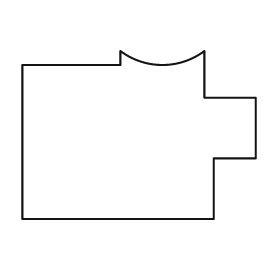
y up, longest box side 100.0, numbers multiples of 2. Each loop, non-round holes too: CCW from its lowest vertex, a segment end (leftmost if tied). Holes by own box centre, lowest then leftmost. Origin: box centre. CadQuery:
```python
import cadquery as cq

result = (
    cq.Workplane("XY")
    .moveTo(-50.0, -36.0)
    .lineTo(32.0, -36.0)
    .lineTo(32.0, -10.0)
    .lineTo(50.0, -10.0)
    .lineTo(50.0, 16.0)
    .lineTo(28.0, 16.0)
    .lineTo(28.0, 36.0)
    .threePointArc((10.0, 30.0), (-8.0, 36.0))
    .lineTo(-8.0, 30.0)
    .lineTo(-50.0, 30.0)
    .close()
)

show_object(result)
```